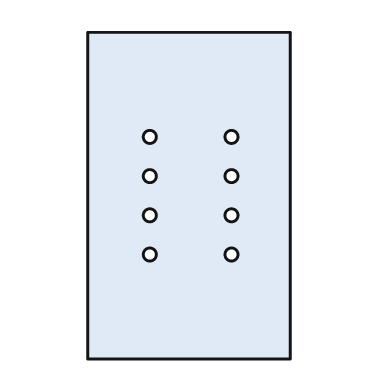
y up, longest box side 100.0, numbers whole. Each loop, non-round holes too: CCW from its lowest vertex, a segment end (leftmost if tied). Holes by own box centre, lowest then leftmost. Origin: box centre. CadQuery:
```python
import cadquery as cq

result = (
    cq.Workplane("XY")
    .moveTo(-31.0, -50.0)
    .lineTo(31.0, -50.0)
    .lineTo(31.0, 50.0)
    .lineTo(-31.0, 50.0)
    .close()
    .moveTo(-12.0, -18.0)
    .circle(2.0)
    .moveTo(13.0, -18.0)
    .circle(2.0)
    .moveTo(-12.0, -6.0)
    .circle(2.0)
    .moveTo(13.0, -6.0)
    .circle(2.0)
    .moveTo(-12.0, 6.0)
    .circle(2.0)
    .moveTo(13.0, 6.0)
    .circle(2.0)
    .moveTo(-12.0, 18.0)
    .circle(2.0)
    .moveTo(13.0, 18.0)
    .circle(2.0)
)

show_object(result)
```